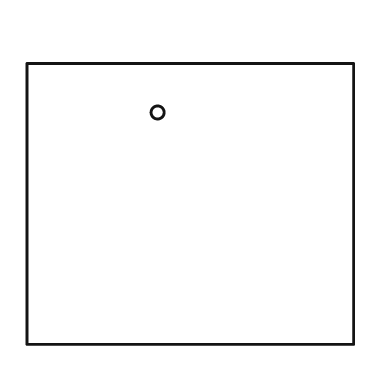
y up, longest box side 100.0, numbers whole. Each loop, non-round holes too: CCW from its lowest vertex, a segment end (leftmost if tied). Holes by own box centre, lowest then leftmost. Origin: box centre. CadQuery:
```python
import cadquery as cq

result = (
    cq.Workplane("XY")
    .moveTo(-50.0, -43.0)
    .lineTo(50.0, -43.0)
    .lineTo(50.0, 43.0)
    .lineTo(-50.0, 43.0)
    .close()
    .moveTo(-10.0, 28.0)
    .circle(2.0)
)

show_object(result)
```